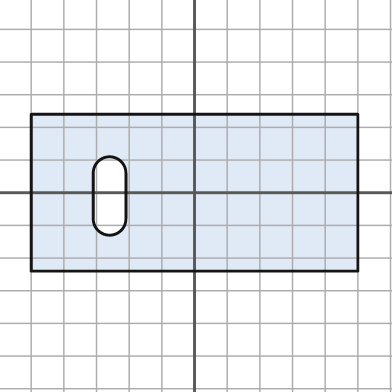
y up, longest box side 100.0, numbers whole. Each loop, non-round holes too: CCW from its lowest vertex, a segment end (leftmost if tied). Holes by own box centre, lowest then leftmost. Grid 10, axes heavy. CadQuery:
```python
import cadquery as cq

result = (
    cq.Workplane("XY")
    .moveTo(-50.0, -24.0)
    .lineTo(50.0, -24.0)
    .lineTo(50.0, 24.0)
    .lineTo(-50.0, 24.0)
    .close()
    .moveTo(-31.0, -8.0)
    .threePointArc((-26.0, -13.0), (-21.0, -8.0))
    .lineTo(-21.0, 6.0)
    .threePointArc((-26.0, 11.0), (-31.0, 6.0))
    .close()
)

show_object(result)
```